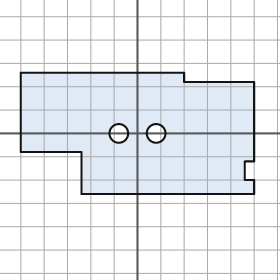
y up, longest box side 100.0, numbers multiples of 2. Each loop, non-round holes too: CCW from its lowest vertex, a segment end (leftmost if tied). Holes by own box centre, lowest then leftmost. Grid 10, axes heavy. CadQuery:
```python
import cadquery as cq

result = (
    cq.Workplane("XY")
    .moveTo(-24.0, -26.0)
    .lineTo(50.0, -26.0)
    .lineTo(50.0, -20.0)
    .lineTo(46.0, -20.0)
    .lineTo(46.0, -12.0)
    .lineTo(50.0, -12.0)
    .lineTo(50.0, 22.0)
    .lineTo(20.0, 22.0)
    .lineTo(20.0, 26.0)
    .lineTo(-50.0, 26.0)
    .lineTo(-50.0, -8.0)
    .lineTo(-24.0, -8.0)
    .close()
    .moveTo(-8.0, 0.0)
    .circle(4.0)
    .moveTo(8.0, 0.0)
    .circle(4.0)
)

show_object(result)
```